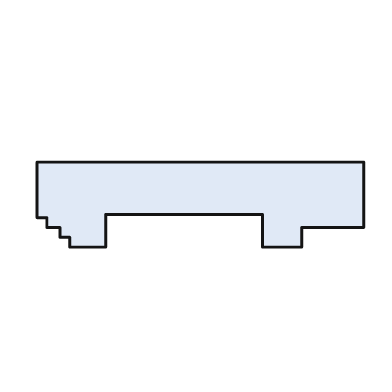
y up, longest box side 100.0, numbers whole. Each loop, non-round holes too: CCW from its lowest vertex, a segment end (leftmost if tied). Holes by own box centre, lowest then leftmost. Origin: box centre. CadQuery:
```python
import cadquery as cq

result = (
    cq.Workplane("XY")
    .moveTo(-40.0, -13.0)
    .lineTo(-29.0, -13.0)
    .lineTo(-29.0, -3.0)
    .lineTo(19.0, -3.0)
    .lineTo(19.0, -13.0)
    .lineTo(31.0, -13.0)
    .lineTo(31.0, -7.0)
    .lineTo(50.0, -7.0)
    .lineTo(50.0, 13.0)
    .lineTo(-50.0, 13.0)
    .lineTo(-50.0, -4.0)
    .lineTo(-47.0, -4.0)
    .lineTo(-47.0, -7.0)
    .lineTo(-43.0, -7.0)
    .lineTo(-43.0, -10.0)
    .lineTo(-40.0, -10.0)
    .close()
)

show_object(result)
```